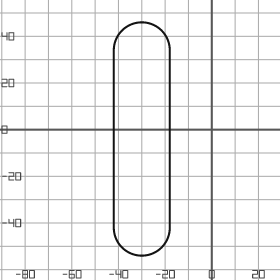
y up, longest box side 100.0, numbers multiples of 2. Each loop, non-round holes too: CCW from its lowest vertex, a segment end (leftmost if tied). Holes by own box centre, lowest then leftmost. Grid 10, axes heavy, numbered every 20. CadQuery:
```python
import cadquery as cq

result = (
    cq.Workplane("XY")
    .moveTo(-42.0, -42.0)
    .threePointArc((-30.0, -54.0), (-18.0, -42.0))
    .lineTo(-18.0, 34.0)
    .threePointArc((-30.0, 46.0), (-42.0, 34.0))
    .close()
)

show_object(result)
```